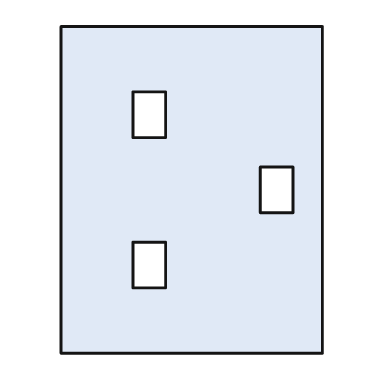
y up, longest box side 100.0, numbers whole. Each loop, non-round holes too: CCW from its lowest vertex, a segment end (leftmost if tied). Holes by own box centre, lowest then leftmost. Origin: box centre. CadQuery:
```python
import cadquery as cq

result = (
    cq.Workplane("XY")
    .moveTo(-40.0, -50.0)
    .lineTo(40.0, -50.0)
    .lineTo(40.0, 50.0)
    .lineTo(-40.0, 50.0)
    .close()
    .moveTo(-18.0, -30.0)
    .lineTo(-8.0, -30.0)
    .lineTo(-8.0, -16.0)
    .lineTo(-18.0, -16.0)
    .close()
    .moveTo(21.0, -7.0)
    .lineTo(31.0, -7.0)
    .lineTo(31.0, 7.0)
    .lineTo(21.0, 7.0)
    .close()
    .moveTo(-18.0, 16.0)
    .lineTo(-8.0, 16.0)
    .lineTo(-8.0, 30.0)
    .lineTo(-18.0, 30.0)
    .close()
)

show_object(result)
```